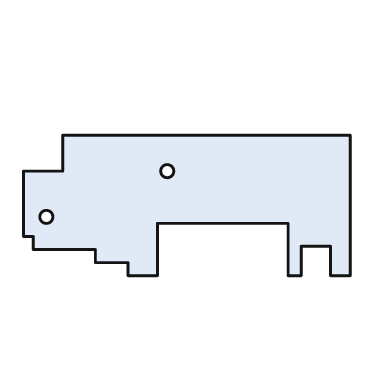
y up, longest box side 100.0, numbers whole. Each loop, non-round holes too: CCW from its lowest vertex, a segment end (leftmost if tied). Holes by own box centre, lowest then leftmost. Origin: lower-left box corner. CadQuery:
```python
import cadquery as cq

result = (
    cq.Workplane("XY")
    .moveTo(32.0, 0.0)
    .lineTo(41.0, 0.0)
    .lineTo(41.0, 16.0)
    .lineTo(81.0, 16.0)
    .lineTo(81.0, 0.0)
    .lineTo(85.0, 0.0)
    .lineTo(85.0, 9.0)
    .lineTo(94.0, 9.0)
    .lineTo(94.0, 0.0)
    .lineTo(100.0, 0.0)
    .lineTo(100.0, 43.0)
    .lineTo(12.0, 43.0)
    .lineTo(12.0, 32.0)
    .lineTo(0.0, 32.0)
    .lineTo(0.0, 12.0)
    .lineTo(3.0, 12.0)
    .lineTo(3.0, 8.0)
    .lineTo(22.0, 8.0)
    .lineTo(22.0, 4.0)
    .lineTo(32.0, 4.0)
    .close()
    .moveTo(7.0, 18.0)
    .circle(2.0)
    .moveTo(44.0, 32.0)
    .circle(2.0)
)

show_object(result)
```